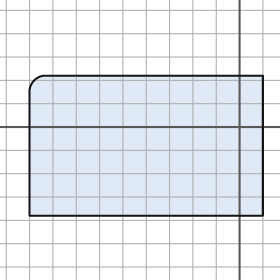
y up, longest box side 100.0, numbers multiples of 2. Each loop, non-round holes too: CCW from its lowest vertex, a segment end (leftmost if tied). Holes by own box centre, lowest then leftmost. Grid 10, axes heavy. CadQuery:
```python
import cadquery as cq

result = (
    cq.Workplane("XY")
    .moveTo(-90.0, -38.0)
    .lineTo(10.0, -38.0)
    .lineTo(10.0, 22.0)
    .lineTo(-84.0, 22.0)
    .threePointArc((-88.0, 20.0), (-90.0, 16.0))
    .close()
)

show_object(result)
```